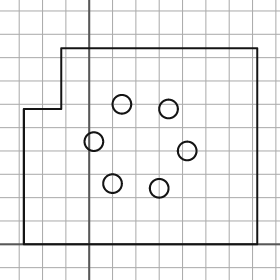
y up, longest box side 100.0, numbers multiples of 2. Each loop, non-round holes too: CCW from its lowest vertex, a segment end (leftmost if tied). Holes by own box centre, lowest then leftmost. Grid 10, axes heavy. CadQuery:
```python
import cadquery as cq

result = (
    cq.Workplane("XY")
    .moveTo(-28.0, 0.0)
    .lineTo(72.0, 0.0)
    .lineTo(72.0, 84.0)
    .lineTo(-12.0, 84.0)
    .lineTo(-12.0, 58.0)
    .lineTo(-28.0, 58.0)
    .close()
    .moveTo(30.0, 24.0)
    .circle(4.0)
    .moveTo(10.0, 26.0)
    .circle(4.0)
    .moveTo(42.0, 40.0)
    .circle(4.0)
    .moveTo(2.0, 44.0)
    .circle(4.0)
    .moveTo(34.0, 58.0)
    .circle(4.0)
    .moveTo(14.0, 60.0)
    .circle(4.0)
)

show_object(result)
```